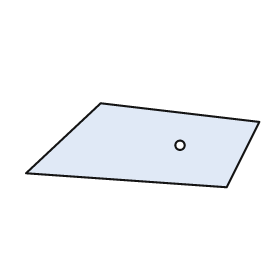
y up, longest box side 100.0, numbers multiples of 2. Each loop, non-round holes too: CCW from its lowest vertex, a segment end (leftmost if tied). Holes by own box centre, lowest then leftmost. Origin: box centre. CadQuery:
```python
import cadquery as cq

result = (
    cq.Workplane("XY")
    .moveTo(36.0, -18.0)
    .lineTo(50.0, 10.0)
    .lineTo(-18.0, 18.0)
    .lineTo(-50.0, -12.0)
    .close()
    .moveTo(16.0, 0.0)
    .circle(2.0)
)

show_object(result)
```